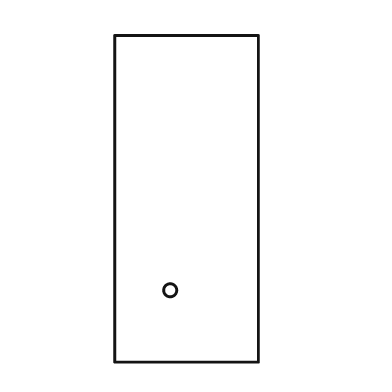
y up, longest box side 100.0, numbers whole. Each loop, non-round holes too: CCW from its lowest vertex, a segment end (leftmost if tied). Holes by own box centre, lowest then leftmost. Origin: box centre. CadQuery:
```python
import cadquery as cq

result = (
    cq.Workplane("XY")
    .moveTo(-22.0, -50.0)
    .lineTo(22.0, -50.0)
    .lineTo(22.0, 50.0)
    .lineTo(-22.0, 50.0)
    .close()
    .moveTo(-5.0, -28.0)
    .circle(2.0)
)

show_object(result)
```